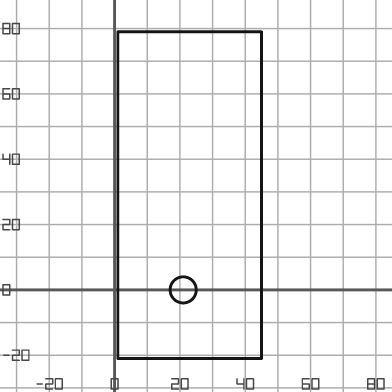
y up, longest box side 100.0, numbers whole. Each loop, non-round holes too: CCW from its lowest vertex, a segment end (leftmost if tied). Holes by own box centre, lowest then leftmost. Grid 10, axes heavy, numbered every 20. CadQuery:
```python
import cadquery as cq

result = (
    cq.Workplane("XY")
    .moveTo(1.0, -21.0)
    .lineTo(45.0, -21.0)
    .lineTo(45.0, 79.0)
    .lineTo(1.0, 79.0)
    .close()
    .moveTo(21.0, 0.0)
    .circle(4.0)
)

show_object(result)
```